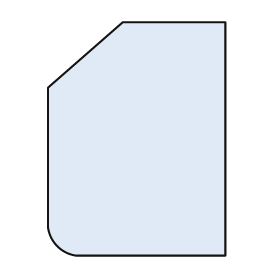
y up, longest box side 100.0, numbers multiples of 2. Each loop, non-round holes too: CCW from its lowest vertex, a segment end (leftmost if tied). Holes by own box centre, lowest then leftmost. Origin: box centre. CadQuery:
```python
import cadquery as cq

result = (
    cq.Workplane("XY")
    .moveTo(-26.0, -50.0)
    .lineTo(38.0, -50.0)
    .lineTo(38.0, 50.0)
    .lineTo(-6.0, 50.0)
    .lineTo(-38.0, 22.0)
    .lineTo(-38.0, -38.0)
    .threePointArc((-34.0, -46.0), (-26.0, -50.0))
    .close()
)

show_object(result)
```